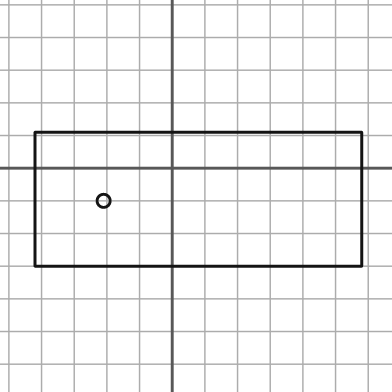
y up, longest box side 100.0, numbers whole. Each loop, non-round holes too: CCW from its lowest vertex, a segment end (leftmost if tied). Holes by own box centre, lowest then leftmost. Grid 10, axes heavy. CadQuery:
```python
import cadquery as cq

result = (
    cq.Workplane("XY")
    .moveTo(-42.0, -30.0)
    .lineTo(58.0, -30.0)
    .lineTo(58.0, 11.0)
    .lineTo(-42.0, 11.0)
    .close()
    .moveTo(-21.0, -10.0)
    .circle(2.0)
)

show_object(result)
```